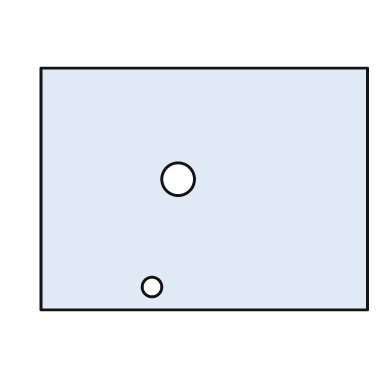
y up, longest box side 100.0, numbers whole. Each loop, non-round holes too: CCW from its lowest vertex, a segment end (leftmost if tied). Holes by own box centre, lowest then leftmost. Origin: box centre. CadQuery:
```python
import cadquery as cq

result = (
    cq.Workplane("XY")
    .moveTo(-50.0, -37.0)
    .lineTo(50.0, -37.0)
    .lineTo(50.0, 37.0)
    .lineTo(-50.0, 37.0)
    .close()
    .moveTo(-16.0, -30.0)
    .circle(3.0)
    .moveTo(-8.0, 3.0)
    .circle(5.0)
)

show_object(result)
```